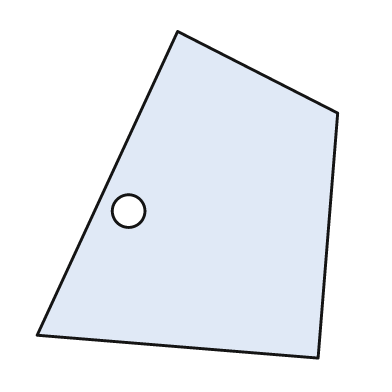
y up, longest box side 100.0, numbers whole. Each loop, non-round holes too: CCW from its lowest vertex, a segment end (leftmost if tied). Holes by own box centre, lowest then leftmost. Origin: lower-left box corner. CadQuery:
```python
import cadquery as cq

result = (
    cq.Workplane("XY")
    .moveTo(86.0, 0.0)
    .lineTo(92.0, 75.0)
    .lineTo(43.0, 100.0)
    .lineTo(0.0, 7.0)
    .close()
    .moveTo(28.0, 45.0)
    .circle(5.0)
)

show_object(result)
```